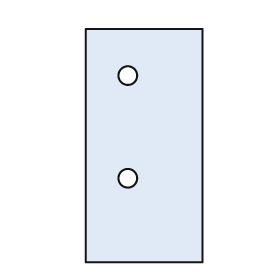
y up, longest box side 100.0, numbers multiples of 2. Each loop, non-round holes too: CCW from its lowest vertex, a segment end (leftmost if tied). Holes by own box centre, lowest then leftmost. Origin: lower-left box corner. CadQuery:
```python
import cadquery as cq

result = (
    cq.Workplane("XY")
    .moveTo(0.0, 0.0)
    .lineTo(50.0, 0.0)
    .lineTo(50.0, 100.0)
    .lineTo(0.0, 100.0)
    .close()
    .moveTo(18.0, 36.0)
    .circle(4.0)
    .moveTo(18.0, 80.0)
    .circle(4.0)
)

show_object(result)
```